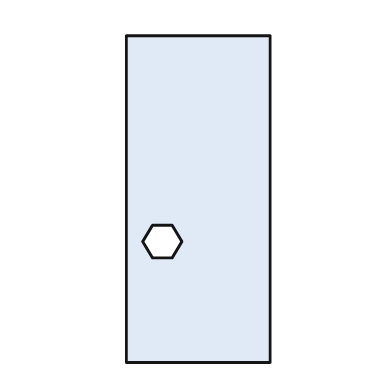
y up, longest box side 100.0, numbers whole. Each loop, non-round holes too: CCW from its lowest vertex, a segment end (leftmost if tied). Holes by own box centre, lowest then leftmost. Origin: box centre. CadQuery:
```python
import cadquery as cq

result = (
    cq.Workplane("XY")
    .moveTo(-22.0, -50.0)
    .lineTo(22.0, -50.0)
    .lineTo(22.0, 50.0)
    .lineTo(-22.0, 50.0)
    .close()
    .moveTo(-14.0, -18.0)
    .lineTo(-8.0, -18.0)
    .lineTo(-5.0, -13.0)
    .lineTo(-8.0, -8.0)
    .lineTo(-14.0, -8.0)
    .lineTo(-17.0, -13.0)
    .close()
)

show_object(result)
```